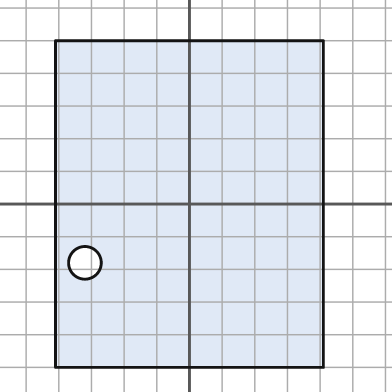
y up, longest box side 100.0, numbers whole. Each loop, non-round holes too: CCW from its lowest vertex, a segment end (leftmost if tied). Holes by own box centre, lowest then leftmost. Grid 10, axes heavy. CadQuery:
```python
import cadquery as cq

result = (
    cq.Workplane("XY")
    .moveTo(-41.0, -50.0)
    .lineTo(41.0, -50.0)
    .lineTo(41.0, 50.0)
    .lineTo(-41.0, 50.0)
    .close()
    .moveTo(-32.0, -18.0)
    .circle(5.0)
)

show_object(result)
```